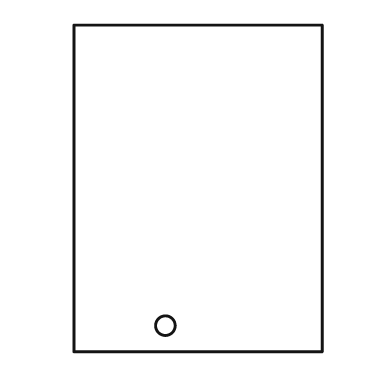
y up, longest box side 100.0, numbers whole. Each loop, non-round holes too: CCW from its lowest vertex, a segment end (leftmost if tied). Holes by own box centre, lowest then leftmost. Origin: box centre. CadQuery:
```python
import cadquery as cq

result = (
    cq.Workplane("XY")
    .moveTo(-38.0, -50.0)
    .lineTo(38.0, -50.0)
    .lineTo(38.0, 50.0)
    .lineTo(-38.0, 50.0)
    .close()
    .moveTo(-10.0, -42.0)
    .circle(3.0)
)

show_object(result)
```